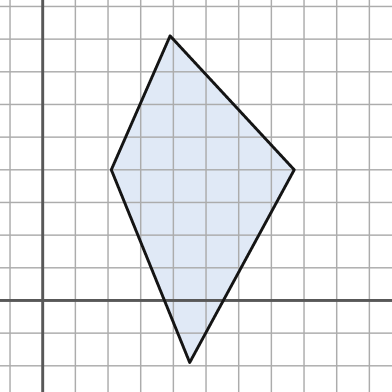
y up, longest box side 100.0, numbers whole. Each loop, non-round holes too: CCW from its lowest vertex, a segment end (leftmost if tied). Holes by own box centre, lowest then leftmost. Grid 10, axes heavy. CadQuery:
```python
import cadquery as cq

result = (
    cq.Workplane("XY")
    .moveTo(45.0, -19.0)
    .lineTo(77.0, 40.0)
    .lineTo(39.0, 81.0)
    .lineTo(21.0, 40.0)
    .close()
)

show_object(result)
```